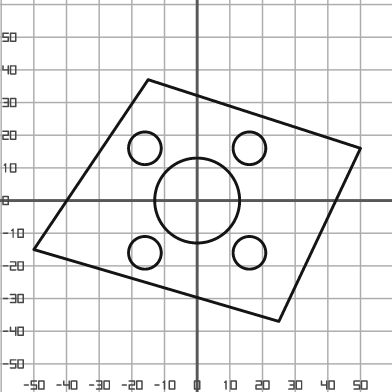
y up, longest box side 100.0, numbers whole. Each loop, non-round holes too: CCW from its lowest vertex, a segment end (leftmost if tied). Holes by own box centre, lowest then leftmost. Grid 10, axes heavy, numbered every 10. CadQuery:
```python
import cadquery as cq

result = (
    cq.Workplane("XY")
    .moveTo(25.0, -37.0)
    .lineTo(50.0, 16.0)
    .lineTo(-15.0, 37.0)
    .lineTo(-50.0, -15.0)
    .close()
    .moveTo(-16.0, -16.0)
    .circle(5.0)
    .moveTo(16.0, -16.0)
    .circle(5.0)
    .moveTo(0.0, 0.0)
    .circle(13.0)
    .moveTo(-16.0, 16.0)
    .circle(5.0)
    .moveTo(16.0, 16.0)
    .circle(5.0)
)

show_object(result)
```